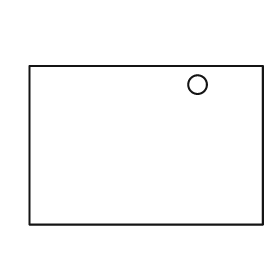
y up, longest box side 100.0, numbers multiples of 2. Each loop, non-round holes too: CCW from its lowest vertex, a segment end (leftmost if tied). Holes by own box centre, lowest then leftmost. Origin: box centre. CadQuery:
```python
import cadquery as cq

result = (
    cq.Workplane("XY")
    .moveTo(-50.0, -34.0)
    .lineTo(50.0, -34.0)
    .lineTo(50.0, 34.0)
    .lineTo(-50.0, 34.0)
    .close()
    .moveTo(22.0, 26.0)
    .circle(4.0)
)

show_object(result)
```